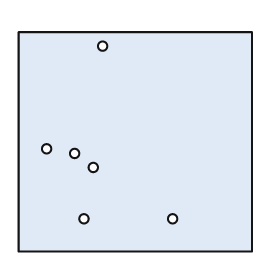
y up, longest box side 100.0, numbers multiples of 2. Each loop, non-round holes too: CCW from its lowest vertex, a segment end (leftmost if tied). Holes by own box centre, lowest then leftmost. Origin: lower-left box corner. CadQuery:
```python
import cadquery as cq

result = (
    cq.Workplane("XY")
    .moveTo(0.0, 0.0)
    .lineTo(100.0, 0.0)
    .lineTo(100.0, 94.0)
    .lineTo(0.0, 94.0)
    .close()
    .moveTo(28.0, 14.0)
    .circle(2.0)
    .moveTo(66.0, 14.0)
    .circle(2.0)
    .moveTo(32.0, 36.0)
    .circle(2.0)
    .moveTo(24.0, 42.0)
    .circle(2.0)
    .moveTo(12.0, 44.0)
    .circle(2.0)
    .moveTo(36.0, 88.0)
    .circle(2.0)
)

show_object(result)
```